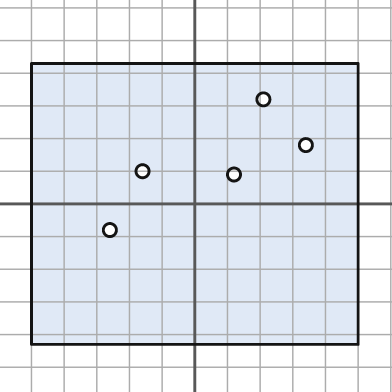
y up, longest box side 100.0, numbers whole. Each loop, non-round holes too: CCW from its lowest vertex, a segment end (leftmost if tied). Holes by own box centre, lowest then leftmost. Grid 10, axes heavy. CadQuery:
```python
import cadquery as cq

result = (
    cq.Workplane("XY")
    .moveTo(-50.0, -43.0)
    .lineTo(50.0, -43.0)
    .lineTo(50.0, 43.0)
    .lineTo(-50.0, 43.0)
    .close()
    .moveTo(-26.0, -8.0)
    .circle(2.0)
    .moveTo(12.0, 9.0)
    .circle(2.0)
    .moveTo(-16.0, 10.0)
    .circle(2.0)
    .moveTo(34.0, 18.0)
    .circle(2.0)
    .moveTo(21.0, 32.0)
    .circle(2.0)
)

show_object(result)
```